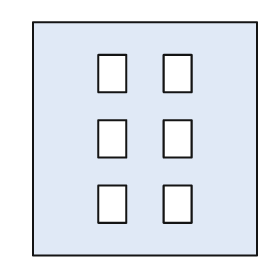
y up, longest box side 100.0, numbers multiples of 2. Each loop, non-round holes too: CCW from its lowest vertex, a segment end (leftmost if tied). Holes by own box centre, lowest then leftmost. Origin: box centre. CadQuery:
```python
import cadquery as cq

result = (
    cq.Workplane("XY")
    .moveTo(-48.0, -50.0)
    .lineTo(48.0, -50.0)
    .lineTo(48.0, 50.0)
    .lineTo(-48.0, 50.0)
    .close()
    .moveTo(-20.0, -36.0)
    .lineTo(-8.0, -36.0)
    .lineTo(-8.0, -20.0)
    .lineTo(-20.0, -20.0)
    .close()
    .moveTo(8.0, -36.0)
    .lineTo(20.0, -36.0)
    .lineTo(20.0, -20.0)
    .lineTo(8.0, -20.0)
    .close()
    .moveTo(-20.0, -8.0)
    .lineTo(-8.0, -8.0)
    .lineTo(-8.0, 8.0)
    .lineTo(-20.0, 8.0)
    .close()
    .moveTo(8.0, -8.0)
    .lineTo(20.0, -8.0)
    .lineTo(20.0, 8.0)
    .lineTo(8.0, 8.0)
    .close()
    .moveTo(-20.0, 20.0)
    .lineTo(-8.0, 20.0)
    .lineTo(-8.0, 36.0)
    .lineTo(-20.0, 36.0)
    .close()
    .moveTo(8.0, 20.0)
    .lineTo(20.0, 20.0)
    .lineTo(20.0, 36.0)
    .lineTo(8.0, 36.0)
    .close()
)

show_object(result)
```